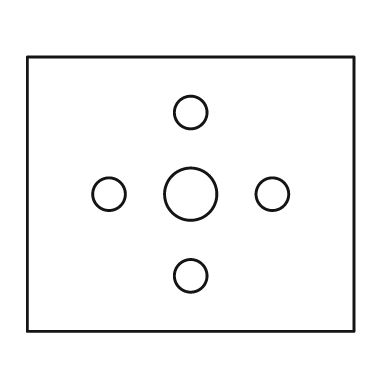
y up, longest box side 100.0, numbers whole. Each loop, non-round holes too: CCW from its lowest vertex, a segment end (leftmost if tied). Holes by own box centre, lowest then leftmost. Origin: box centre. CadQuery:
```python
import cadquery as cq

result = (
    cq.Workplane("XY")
    .moveTo(-50.0, -42.0)
    .lineTo(50.0, -42.0)
    .lineTo(50.0, 42.0)
    .lineTo(-50.0, 42.0)
    .close()
    .moveTo(0.0, -25.0)
    .circle(5.0)
    .moveTo(-25.0, 0.0)
    .circle(5.0)
    .moveTo(0.0, 0.0)
    .circle(8.0)
    .moveTo(25.0, 0.0)
    .circle(5.0)
    .moveTo(0.0, 25.0)
    .circle(5.0)
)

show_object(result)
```